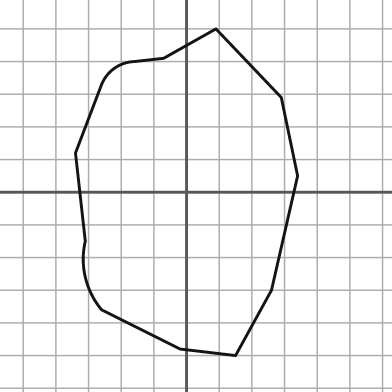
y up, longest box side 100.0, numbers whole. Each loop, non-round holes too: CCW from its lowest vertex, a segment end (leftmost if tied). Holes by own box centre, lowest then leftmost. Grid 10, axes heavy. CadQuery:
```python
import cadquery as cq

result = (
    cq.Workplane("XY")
    .moveTo(15.0, -50.0)
    .lineTo(26.0, -30.0)
    .lineTo(34.0, 5.0)
    .lineTo(29.0, 29.0)
    .lineTo(9.0, 50.0)
    .lineTo(-7.0, 41.0)
    .lineTo(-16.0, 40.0)
    .threePointArc((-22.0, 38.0), (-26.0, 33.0))
    .lineTo(-34.0, 12.0)
    .lineTo(-31.0, -15.0)
    .threePointArc((-31.0, -26.0), (-26.0, -36.0))
    .lineTo(-2.0, -48.0)
    .close()
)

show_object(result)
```